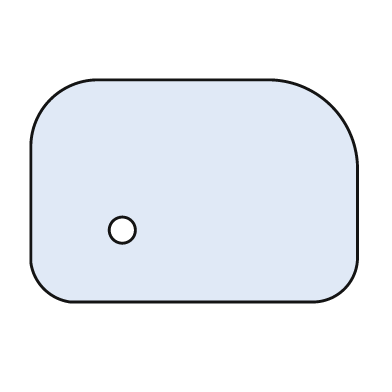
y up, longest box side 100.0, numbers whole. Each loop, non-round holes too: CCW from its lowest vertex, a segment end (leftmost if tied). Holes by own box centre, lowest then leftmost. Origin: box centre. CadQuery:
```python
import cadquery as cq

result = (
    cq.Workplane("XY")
    .moveTo(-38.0, -34.0)
    .lineTo(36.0, -34.0)
    .threePointArc((46.0, -30.0), (50.0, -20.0))
    .lineTo(50.0, 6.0)
    .threePointArc((42.0, 26.0), (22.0, 34.0))
    .lineTo(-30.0, 34.0)
    .threePointArc((-44.0, 28.0), (-50.0, 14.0))
    .lineTo(-50.0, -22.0)
    .threePointArc((-46.0, -30.0), (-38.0, -34.0))
    .close()
    .moveTo(-22.0, -12.0)
    .circle(4.0)
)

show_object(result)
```